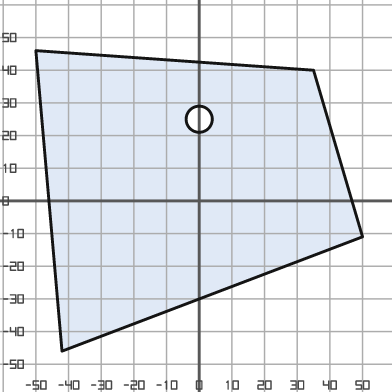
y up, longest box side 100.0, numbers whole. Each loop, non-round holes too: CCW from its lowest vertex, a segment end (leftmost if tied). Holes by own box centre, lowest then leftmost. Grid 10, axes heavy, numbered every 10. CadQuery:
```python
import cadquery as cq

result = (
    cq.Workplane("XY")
    .moveTo(-42.0, -46.0)
    .lineTo(50.0, -11.0)
    .lineTo(35.0, 40.0)
    .lineTo(-50.0, 46.0)
    .close()
    .moveTo(0.0, 25.0)
    .circle(4.0)
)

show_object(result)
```